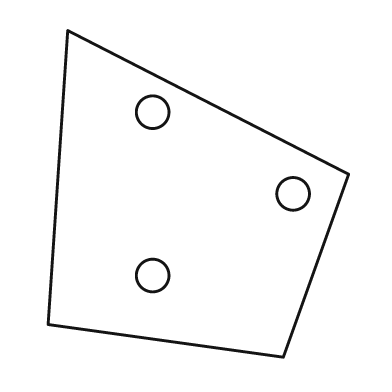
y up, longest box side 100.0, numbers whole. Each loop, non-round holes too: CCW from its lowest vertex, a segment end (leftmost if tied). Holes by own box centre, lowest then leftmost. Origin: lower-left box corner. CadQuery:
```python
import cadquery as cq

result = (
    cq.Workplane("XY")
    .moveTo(72.0, 0.0)
    .lineTo(92.0, 56.0)
    .lineTo(6.0, 100.0)
    .lineTo(0.0, 10.0)
    .close()
    .moveTo(32.0, 25.0)
    .circle(5.0)
    .moveTo(75.0, 50.0)
    .circle(5.0)
    .moveTo(32.0, 75.0)
    .circle(5.0)
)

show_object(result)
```